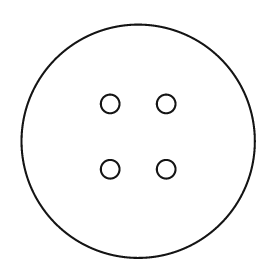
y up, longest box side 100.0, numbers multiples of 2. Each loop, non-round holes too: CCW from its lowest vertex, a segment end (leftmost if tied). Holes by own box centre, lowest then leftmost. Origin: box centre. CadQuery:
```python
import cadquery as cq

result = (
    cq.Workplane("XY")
    .moveTo(0.0, 0.0)
    .circle(50.0)
    .moveTo(-12.0, -12.0)
    .circle(4.0)
    .moveTo(12.0, -12.0)
    .circle(4.0)
    .moveTo(-12.0, 16.0)
    .circle(4.0)
    .moveTo(12.0, 16.0)
    .circle(4.0)
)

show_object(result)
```